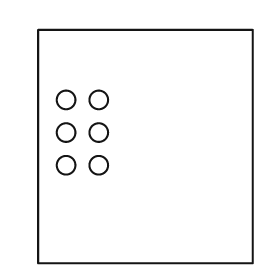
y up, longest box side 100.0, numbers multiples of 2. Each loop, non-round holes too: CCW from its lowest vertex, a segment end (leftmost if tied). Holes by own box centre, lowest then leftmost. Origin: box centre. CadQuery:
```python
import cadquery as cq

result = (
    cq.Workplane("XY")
    .moveTo(-46.0, -50.0)
    .lineTo(46.0, -50.0)
    .lineTo(46.0, 50.0)
    .lineTo(-46.0, 50.0)
    .close()
    .moveTo(-34.0, -8.0)
    .circle(4.0)
    .moveTo(-20.0, -8.0)
    .circle(4.0)
    .moveTo(-34.0, 6.0)
    .circle(4.0)
    .moveTo(-20.0, 6.0)
    .circle(4.0)
    .moveTo(-34.0, 20.0)
    .circle(4.0)
    .moveTo(-20.0, 20.0)
    .circle(4.0)
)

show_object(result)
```